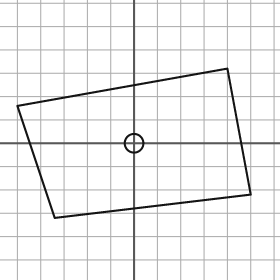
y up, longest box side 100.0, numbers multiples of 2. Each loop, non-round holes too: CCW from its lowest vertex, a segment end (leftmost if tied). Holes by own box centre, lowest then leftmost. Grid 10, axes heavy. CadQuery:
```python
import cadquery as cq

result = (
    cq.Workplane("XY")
    .moveTo(-34.0, -32.0)
    .lineTo(50.0, -22.0)
    .lineTo(40.0, 32.0)
    .lineTo(-50.0, 16.0)
    .close()
    .moveTo(0.0, 0.0)
    .circle(4.0)
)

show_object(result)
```